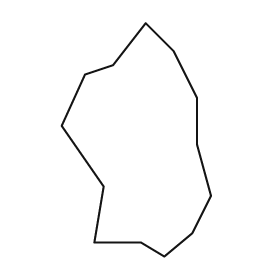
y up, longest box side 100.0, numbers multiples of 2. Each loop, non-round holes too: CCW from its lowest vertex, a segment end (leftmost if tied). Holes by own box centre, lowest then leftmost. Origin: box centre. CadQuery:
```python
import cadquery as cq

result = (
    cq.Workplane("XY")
    .moveTo(12.0, -50.0)
    .lineTo(24.0, -40.0)
    .lineTo(32.0, -24.0)
    .lineTo(26.0, -2.0)
    .lineTo(26.0, 18.0)
    .lineTo(16.0, 38.0)
    .lineTo(4.0, 50.0)
    .lineTo(-10.0, 32.0)
    .lineTo(-22.0, 28.0)
    .lineTo(-32.0, 6.0)
    .lineTo(-14.0, -20.0)
    .lineTo(-18.0, -44.0)
    .lineTo(2.0, -44.0)
    .close()
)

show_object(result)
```